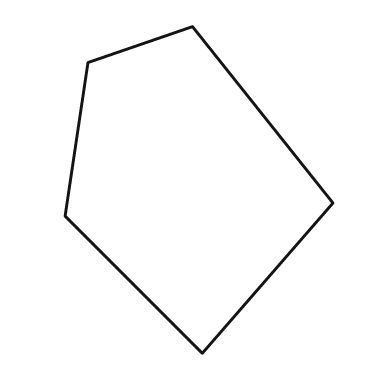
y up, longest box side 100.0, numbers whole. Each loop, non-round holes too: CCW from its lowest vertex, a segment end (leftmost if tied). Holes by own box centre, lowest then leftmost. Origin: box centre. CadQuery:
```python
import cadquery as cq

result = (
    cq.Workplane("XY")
    .moveTo(1.0, -50.0)
    .lineTo(41.0, -4.0)
    .lineTo(-2.0, 50.0)
    .lineTo(-34.0, 39.0)
    .lineTo(-41.0, -8.0)
    .close()
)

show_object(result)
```